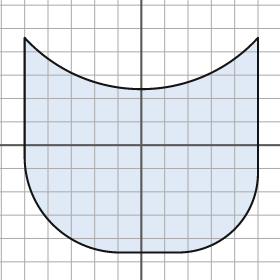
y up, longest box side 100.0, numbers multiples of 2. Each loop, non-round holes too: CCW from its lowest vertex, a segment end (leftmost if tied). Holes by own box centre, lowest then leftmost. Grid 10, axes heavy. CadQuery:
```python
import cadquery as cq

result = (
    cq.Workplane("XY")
    .moveTo(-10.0, -46.0)
    .lineTo(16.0, -46.0)
    .threePointArc((40.0, -36.0), (50.0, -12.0))
    .lineTo(50.0, 46.0)
    .threePointArc((0.0, 24.0), (-50.0, 46.0))
    .lineTo(-50.0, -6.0)
    .threePointArc((-38.0, -34.0), (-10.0, -46.0))
    .close()
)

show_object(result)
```